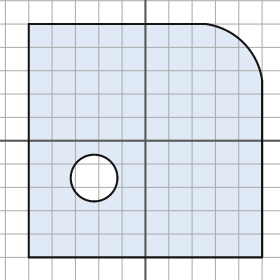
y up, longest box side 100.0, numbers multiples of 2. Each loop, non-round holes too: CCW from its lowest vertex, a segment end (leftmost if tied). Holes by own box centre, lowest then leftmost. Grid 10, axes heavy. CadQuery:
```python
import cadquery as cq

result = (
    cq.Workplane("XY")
    .moveTo(-50.0, -50.0)
    .lineTo(50.0, -50.0)
    .lineTo(50.0, 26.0)
    .threePointArc((42.0, 42.0), (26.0, 50.0))
    .lineTo(-50.0, 50.0)
    .close()
    .moveTo(-22.0, -16.0)
    .circle(10.0)
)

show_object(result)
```